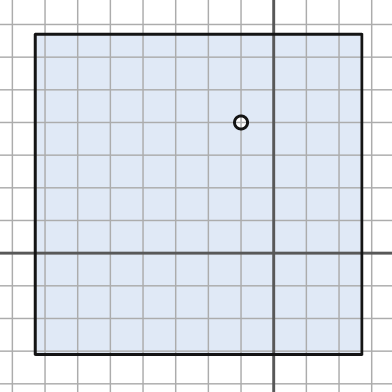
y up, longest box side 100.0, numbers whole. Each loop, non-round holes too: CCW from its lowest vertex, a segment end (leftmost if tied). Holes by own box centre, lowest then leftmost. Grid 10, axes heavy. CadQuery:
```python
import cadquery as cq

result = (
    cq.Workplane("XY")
    .moveTo(-73.0, -31.0)
    .lineTo(27.0, -31.0)
    .lineTo(27.0, 67.0)
    .lineTo(-73.0, 67.0)
    .close()
    .moveTo(-10.0, 40.0)
    .circle(2.0)
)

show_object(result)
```